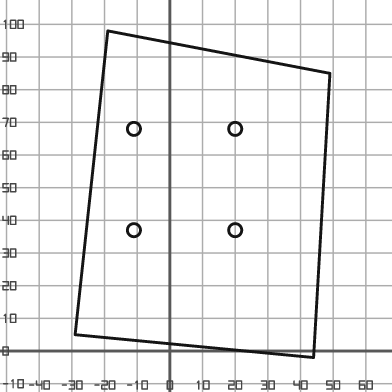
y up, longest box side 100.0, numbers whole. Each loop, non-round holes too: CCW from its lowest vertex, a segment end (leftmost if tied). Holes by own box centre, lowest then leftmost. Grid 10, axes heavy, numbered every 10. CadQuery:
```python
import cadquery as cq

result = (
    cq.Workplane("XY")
    .moveTo(44.0, -2.0)
    .lineTo(49.0, 85.0)
    .lineTo(-19.0, 98.0)
    .lineTo(-29.0, 5.0)
    .close()
    .moveTo(-11.0, 37.0)
    .circle(2.0)
    .moveTo(20.0, 37.0)
    .circle(2.0)
    .moveTo(-11.0, 68.0)
    .circle(2.0)
    .moveTo(20.0, 68.0)
    .circle(2.0)
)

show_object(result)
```